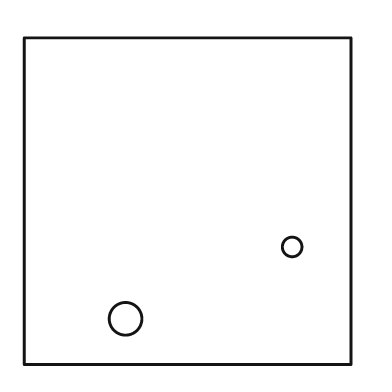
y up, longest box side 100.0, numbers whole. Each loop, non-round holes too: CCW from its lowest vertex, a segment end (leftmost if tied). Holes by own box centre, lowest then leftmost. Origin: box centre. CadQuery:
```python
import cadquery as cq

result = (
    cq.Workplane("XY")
    .moveTo(-50.0, -50.0)
    .lineTo(50.0, -50.0)
    .lineTo(50.0, 50.0)
    .lineTo(-50.0, 50.0)
    .close()
    .moveTo(-19.0, -36.0)
    .circle(5.0)
    .moveTo(32.0, -14.0)
    .circle(3.0)
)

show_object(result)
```